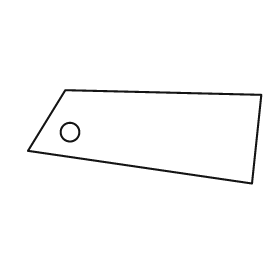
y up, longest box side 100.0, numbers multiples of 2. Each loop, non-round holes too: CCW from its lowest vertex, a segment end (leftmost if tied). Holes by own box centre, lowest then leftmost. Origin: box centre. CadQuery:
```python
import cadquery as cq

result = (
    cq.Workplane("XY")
    .moveTo(46.0, -20.0)
    .lineTo(50.0, 18.0)
    .lineTo(-34.0, 20.0)
    .lineTo(-50.0, -6.0)
    .close()
    .moveTo(-32.0, 2.0)
    .circle(4.0)
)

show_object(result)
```